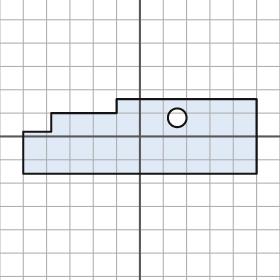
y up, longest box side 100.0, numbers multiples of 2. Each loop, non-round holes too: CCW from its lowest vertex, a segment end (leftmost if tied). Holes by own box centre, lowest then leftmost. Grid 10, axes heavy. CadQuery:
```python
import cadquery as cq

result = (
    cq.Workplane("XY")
    .moveTo(-50.0, -16.0)
    .lineTo(50.0, -16.0)
    .lineTo(50.0, 16.0)
    .lineTo(-10.0, 16.0)
    .lineTo(-10.0, 10.0)
    .lineTo(-38.0, 10.0)
    .lineTo(-38.0, 2.0)
    .lineTo(-50.0, 2.0)
    .close()
    .moveTo(16.0, 8.0)
    .circle(4.0)
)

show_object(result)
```